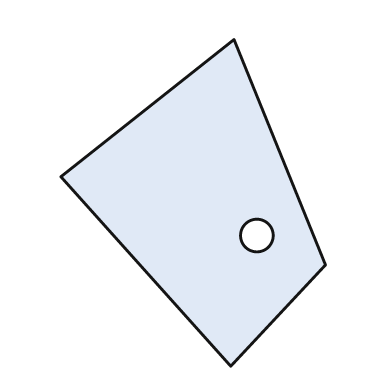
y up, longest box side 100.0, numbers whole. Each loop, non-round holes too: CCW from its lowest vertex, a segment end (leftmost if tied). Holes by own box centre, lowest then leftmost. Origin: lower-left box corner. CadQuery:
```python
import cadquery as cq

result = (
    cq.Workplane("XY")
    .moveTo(52.0, 0.0)
    .lineTo(81.0, 31.0)
    .lineTo(53.0, 100.0)
    .lineTo(0.0, 58.0)
    .close()
    .moveTo(60.0, 40.0)
    .circle(5.0)
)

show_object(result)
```